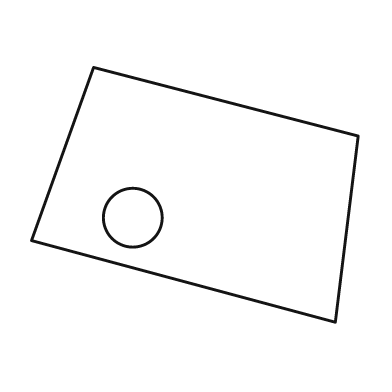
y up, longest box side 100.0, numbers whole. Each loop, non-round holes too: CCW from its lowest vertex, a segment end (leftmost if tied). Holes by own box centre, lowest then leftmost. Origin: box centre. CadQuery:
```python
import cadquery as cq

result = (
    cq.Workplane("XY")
    .moveTo(43.0, -39.0)
    .lineTo(50.0, 18.0)
    .lineTo(-31.0, 39.0)
    .lineTo(-50.0, -14.0)
    .close()
    .moveTo(-19.0, -7.0)
    .circle(9.0)
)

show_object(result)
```